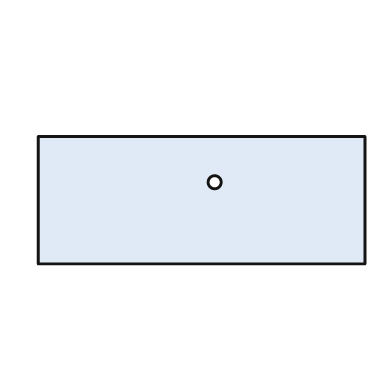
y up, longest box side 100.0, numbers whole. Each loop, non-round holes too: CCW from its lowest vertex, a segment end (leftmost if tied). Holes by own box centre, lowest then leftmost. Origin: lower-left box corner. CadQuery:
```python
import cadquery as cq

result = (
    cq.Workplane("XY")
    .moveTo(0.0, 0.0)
    .lineTo(100.0, 0.0)
    .lineTo(100.0, 39.0)
    .lineTo(0.0, 39.0)
    .close()
    .moveTo(54.0, 25.0)
    .circle(2.0)
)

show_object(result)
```